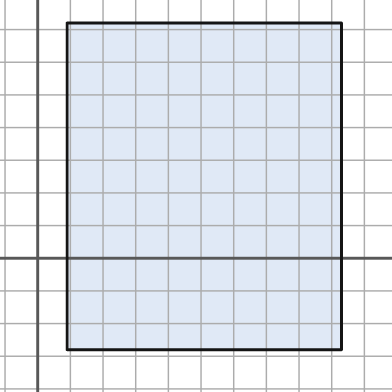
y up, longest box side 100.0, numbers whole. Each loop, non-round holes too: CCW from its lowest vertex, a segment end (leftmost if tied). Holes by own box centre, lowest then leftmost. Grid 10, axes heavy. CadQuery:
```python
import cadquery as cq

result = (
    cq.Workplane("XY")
    .moveTo(9.0, -28.0)
    .lineTo(93.0, -28.0)
    .lineTo(93.0, 72.0)
    .lineTo(9.0, 72.0)
    .close()
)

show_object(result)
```